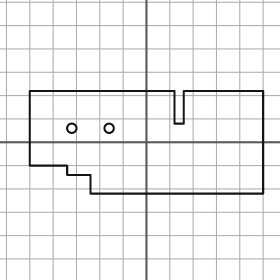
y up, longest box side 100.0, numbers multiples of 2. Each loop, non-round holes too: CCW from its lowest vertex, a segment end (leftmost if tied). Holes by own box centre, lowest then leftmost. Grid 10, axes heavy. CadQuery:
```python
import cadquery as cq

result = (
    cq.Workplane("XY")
    .moveTo(-24.0, -22.0)
    .lineTo(50.0, -22.0)
    .lineTo(50.0, 22.0)
    .lineTo(16.0, 22.0)
    .lineTo(16.0, 8.0)
    .lineTo(12.0, 8.0)
    .lineTo(12.0, 22.0)
    .lineTo(-50.0, 22.0)
    .lineTo(-50.0, -10.0)
    .lineTo(-34.0, -10.0)
    .lineTo(-34.0, -14.0)
    .lineTo(-24.0, -14.0)
    .close()
    .moveTo(-32.0, 6.0)
    .circle(2.0)
    .moveTo(-16.0, 6.0)
    .circle(2.0)
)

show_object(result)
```